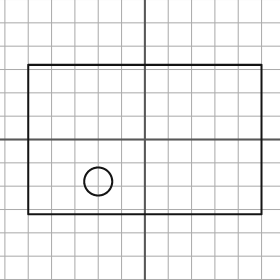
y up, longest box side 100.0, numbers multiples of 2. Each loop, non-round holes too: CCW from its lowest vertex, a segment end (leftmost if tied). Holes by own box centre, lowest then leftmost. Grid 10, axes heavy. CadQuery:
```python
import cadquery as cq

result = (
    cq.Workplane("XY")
    .moveTo(-50.0, -32.0)
    .lineTo(50.0, -32.0)
    .lineTo(50.0, 32.0)
    .lineTo(-50.0, 32.0)
    .close()
    .moveTo(-20.0, -18.0)
    .circle(6.0)
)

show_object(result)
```